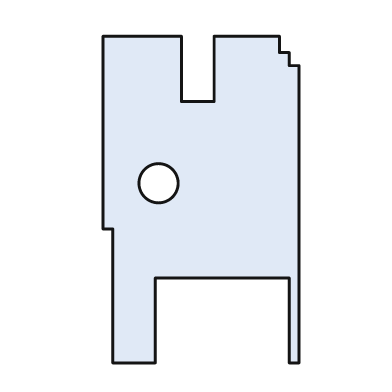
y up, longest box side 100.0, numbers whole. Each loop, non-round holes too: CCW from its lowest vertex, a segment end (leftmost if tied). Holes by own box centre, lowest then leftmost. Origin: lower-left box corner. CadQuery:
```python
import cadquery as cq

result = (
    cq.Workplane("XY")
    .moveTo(3.0, 0.0)
    .lineTo(16.0, 0.0)
    .lineTo(16.0, 26.0)
    .lineTo(57.0, 26.0)
    .lineTo(57.0, 0.0)
    .lineTo(60.0, 0.0)
    .lineTo(60.0, 91.0)
    .lineTo(57.0, 91.0)
    .lineTo(57.0, 95.0)
    .lineTo(54.0, 95.0)
    .lineTo(54.0, 100.0)
    .lineTo(34.0, 100.0)
    .lineTo(34.0, 80.0)
    .lineTo(24.0, 80.0)
    .lineTo(24.0, 100.0)
    .lineTo(0.0, 100.0)
    .lineTo(0.0, 41.0)
    .lineTo(3.0, 41.0)
    .close()
    .moveTo(17.0, 55.0)
    .circle(6.0)
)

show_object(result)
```